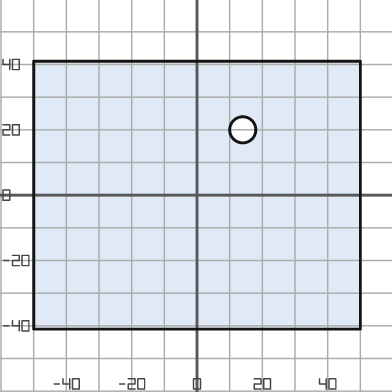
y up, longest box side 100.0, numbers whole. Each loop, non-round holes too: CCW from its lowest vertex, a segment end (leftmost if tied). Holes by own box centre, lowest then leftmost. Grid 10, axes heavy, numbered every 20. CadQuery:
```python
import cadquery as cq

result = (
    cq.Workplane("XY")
    .moveTo(-50.0, -41.0)
    .lineTo(50.0, -41.0)
    .lineTo(50.0, 41.0)
    .lineTo(-50.0, 41.0)
    .close()
    .moveTo(14.0, 20.0)
    .circle(4.0)
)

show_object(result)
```